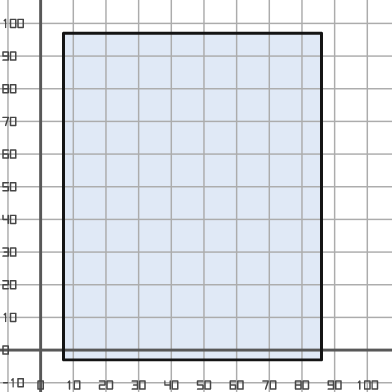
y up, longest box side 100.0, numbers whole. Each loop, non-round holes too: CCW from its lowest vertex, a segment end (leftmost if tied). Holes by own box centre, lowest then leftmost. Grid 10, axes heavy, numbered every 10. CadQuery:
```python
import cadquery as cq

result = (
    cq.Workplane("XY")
    .moveTo(7.0, -3.0)
    .lineTo(86.0, -3.0)
    .lineTo(86.0, 97.0)
    .lineTo(7.0, 97.0)
    .close()
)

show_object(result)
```